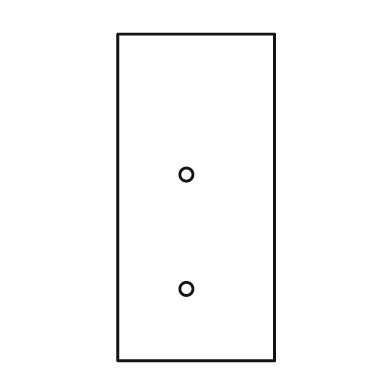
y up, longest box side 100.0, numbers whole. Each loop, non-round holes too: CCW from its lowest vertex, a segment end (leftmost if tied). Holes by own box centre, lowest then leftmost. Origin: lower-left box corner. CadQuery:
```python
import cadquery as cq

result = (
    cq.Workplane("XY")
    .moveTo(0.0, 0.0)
    .lineTo(48.0, 0.0)
    .lineTo(48.0, 100.0)
    .lineTo(0.0, 100.0)
    .close()
    .moveTo(21.0, 22.0)
    .circle(2.0)
    .moveTo(21.0, 57.0)
    .circle(2.0)
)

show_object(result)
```